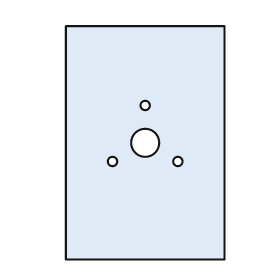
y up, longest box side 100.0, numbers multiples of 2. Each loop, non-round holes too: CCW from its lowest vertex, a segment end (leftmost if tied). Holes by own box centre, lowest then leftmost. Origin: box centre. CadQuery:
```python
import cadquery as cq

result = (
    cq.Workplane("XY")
    .moveTo(-34.0, -50.0)
    .lineTo(34.0, -50.0)
    .lineTo(34.0, 50.0)
    .lineTo(-34.0, 50.0)
    .close()
    .moveTo(-14.0, -8.0)
    .circle(2.0)
    .moveTo(14.0, -8.0)
    .circle(2.0)
    .moveTo(0.0, 0.0)
    .circle(6.0)
    .moveTo(0.0, 16.0)
    .circle(2.0)
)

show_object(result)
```